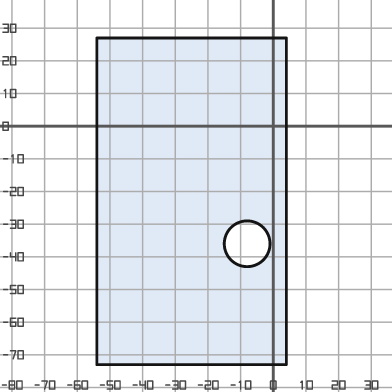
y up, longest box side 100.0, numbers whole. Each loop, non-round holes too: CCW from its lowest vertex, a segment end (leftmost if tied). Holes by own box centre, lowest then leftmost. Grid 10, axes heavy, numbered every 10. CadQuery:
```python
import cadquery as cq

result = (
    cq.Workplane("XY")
    .moveTo(-54.0, -73.0)
    .lineTo(4.0, -73.0)
    .lineTo(4.0, 27.0)
    .lineTo(-54.0, 27.0)
    .close()
    .moveTo(-8.0, -36.0)
    .circle(7.0)
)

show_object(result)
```